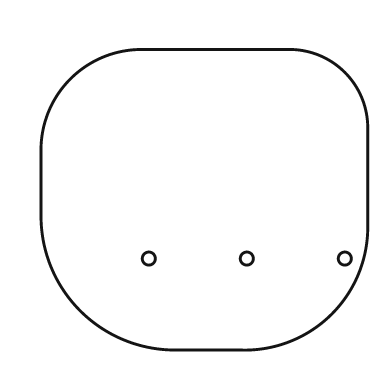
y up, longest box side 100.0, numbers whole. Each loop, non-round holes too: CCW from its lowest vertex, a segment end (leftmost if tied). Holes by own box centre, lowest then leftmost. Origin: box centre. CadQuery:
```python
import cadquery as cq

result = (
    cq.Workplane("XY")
    .moveTo(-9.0, -46.0)
    .lineTo(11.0, -46.0)
    .threePointArc((39.0, -35.0), (50.0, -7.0))
    .lineTo(50.0, 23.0)
    .threePointArc((43.0, 39.0), (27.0, 46.0))
    .lineTo(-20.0, 46.0)
    .threePointArc((-41.0, 37.0), (-50.0, 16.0))
    .lineTo(-50.0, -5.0)
    .threePointArc((-38.0, -34.0), (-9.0, -46.0))
    .close()
    .moveTo(-17.0, -18.0)
    .circle(2.0)
    .moveTo(13.0, -18.0)
    .circle(2.0)
    .moveTo(43.0, -18.0)
    .circle(2.0)
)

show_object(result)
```